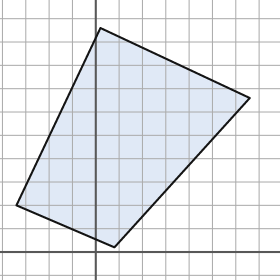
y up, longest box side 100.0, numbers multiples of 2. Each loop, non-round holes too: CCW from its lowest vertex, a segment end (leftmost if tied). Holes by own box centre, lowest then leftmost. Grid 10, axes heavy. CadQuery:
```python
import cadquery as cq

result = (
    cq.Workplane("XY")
    .moveTo(8.0, 2.0)
    .lineTo(66.0, 66.0)
    .lineTo(2.0, 96.0)
    .lineTo(-34.0, 20.0)
    .close()
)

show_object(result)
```